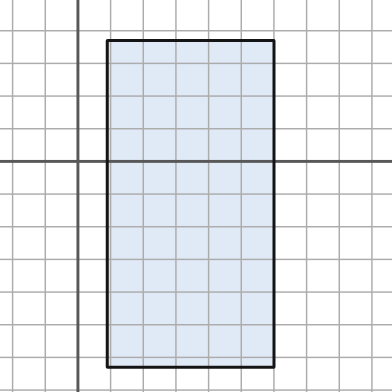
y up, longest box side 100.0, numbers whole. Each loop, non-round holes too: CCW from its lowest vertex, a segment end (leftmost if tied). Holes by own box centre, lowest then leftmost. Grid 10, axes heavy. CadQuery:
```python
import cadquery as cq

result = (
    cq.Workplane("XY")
    .moveTo(9.0, -63.0)
    .lineTo(60.0, -63.0)
    .lineTo(60.0, 37.0)
    .lineTo(9.0, 37.0)
    .close()
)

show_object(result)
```